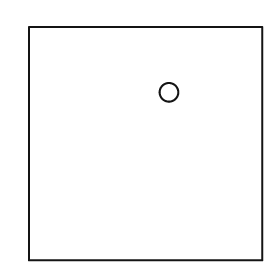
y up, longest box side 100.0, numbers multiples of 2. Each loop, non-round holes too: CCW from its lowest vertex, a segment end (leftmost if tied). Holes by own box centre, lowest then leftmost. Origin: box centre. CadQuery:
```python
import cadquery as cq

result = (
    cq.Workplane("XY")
    .moveTo(-50.0, -50.0)
    .lineTo(50.0, -50.0)
    .lineTo(50.0, 50.0)
    .lineTo(-50.0, 50.0)
    .close()
    .moveTo(10.0, 22.0)
    .circle(4.0)
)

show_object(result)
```